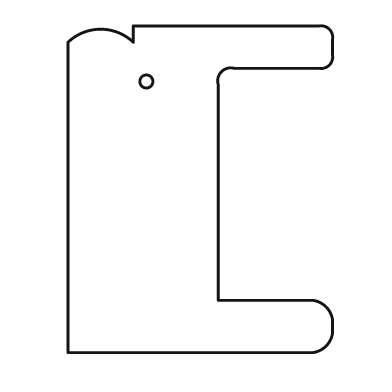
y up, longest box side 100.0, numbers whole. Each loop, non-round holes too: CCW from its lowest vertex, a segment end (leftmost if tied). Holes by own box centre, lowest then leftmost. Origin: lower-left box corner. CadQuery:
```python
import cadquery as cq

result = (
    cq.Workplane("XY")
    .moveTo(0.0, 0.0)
    .lineTo(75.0, 0.0)
    .threePointArc((79.0, 2.0), (81.0, 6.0))
    .lineTo(81.0, 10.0)
    .threePointArc((79.0, 14.0), (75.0, 16.0))
    .lineTo(46.0, 16.0)
    .lineTo(46.0, 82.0)
    .threePointArc((47.0, 86.0), (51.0, 87.0))
    .lineTo(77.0, 87.0)
    .threePointArc((80.0, 88.0), (81.0, 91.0))
    .lineTo(81.0, 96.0)
    .threePointArc((80.0, 99.0), (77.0, 100.0))
    .lineTo(20.0, 100.0)
    .lineTo(20.0, 95.0)
    .threePointArc((10.0, 99.0), (0.0, 95.0))
    .close()
    .moveTo(24.0, 83.0)
    .circle(2.0)
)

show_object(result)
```